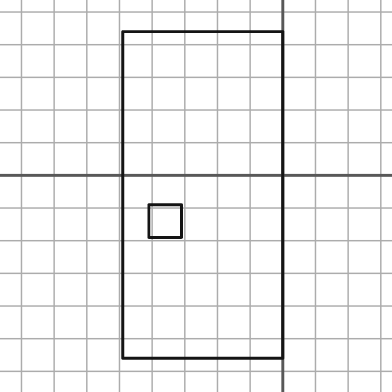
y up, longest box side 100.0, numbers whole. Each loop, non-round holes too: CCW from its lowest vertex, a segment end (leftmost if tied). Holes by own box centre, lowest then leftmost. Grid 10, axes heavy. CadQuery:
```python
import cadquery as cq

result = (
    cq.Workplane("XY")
    .moveTo(-49.0, -56.0)
    .lineTo(0.0, -56.0)
    .lineTo(0.0, 44.0)
    .lineTo(-49.0, 44.0)
    .close()
    .moveTo(-41.0, -19.0)
    .lineTo(-31.0, -19.0)
    .lineTo(-31.0, -9.0)
    .lineTo(-41.0, -9.0)
    .close()
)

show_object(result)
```